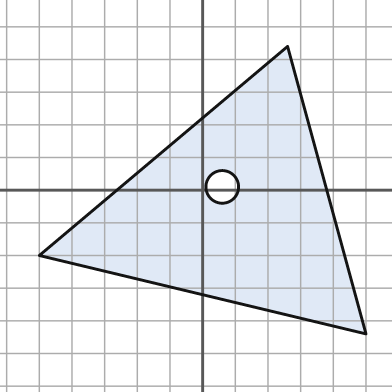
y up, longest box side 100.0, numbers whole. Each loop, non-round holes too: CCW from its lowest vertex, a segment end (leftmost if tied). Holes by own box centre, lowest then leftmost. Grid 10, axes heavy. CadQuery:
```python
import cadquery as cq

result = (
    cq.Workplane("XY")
    .moveTo(50.0, -44.0)
    .lineTo(26.0, 44.0)
    .lineTo(-50.0, -20.0)
    .close()
    .moveTo(6.0, 1.0)
    .circle(5.0)
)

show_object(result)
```